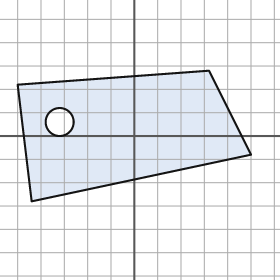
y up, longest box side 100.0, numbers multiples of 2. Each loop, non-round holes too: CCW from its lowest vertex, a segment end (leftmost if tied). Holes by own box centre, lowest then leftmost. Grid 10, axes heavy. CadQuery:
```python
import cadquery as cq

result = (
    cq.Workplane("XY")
    .moveTo(-44.0, -28.0)
    .lineTo(50.0, -8.0)
    .lineTo(32.0, 28.0)
    .lineTo(-50.0, 22.0)
    .close()
    .moveTo(-32.0, 6.0)
    .circle(6.0)
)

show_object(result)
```